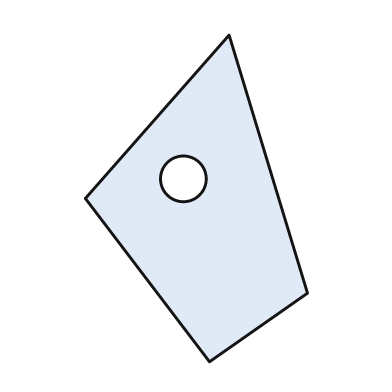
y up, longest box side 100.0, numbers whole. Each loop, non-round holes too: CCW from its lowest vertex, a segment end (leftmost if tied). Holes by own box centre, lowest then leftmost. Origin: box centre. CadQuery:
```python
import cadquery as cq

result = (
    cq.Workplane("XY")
    .moveTo(4.0, -50.0)
    .lineTo(34.0, -29.0)
    .lineTo(10.0, 50.0)
    .lineTo(-34.0, 0.0)
    .close()
    .moveTo(-4.0, 6.0)
    .circle(7.0)
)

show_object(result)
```